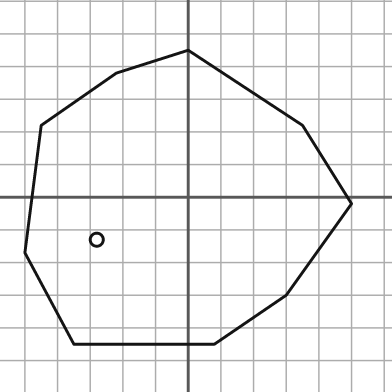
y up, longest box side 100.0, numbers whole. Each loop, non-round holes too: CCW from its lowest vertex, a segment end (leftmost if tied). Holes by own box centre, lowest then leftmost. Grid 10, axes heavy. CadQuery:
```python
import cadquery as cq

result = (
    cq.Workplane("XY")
    .moveTo(-35.0, -45.0)
    .lineTo(8.0, -45.0)
    .lineTo(30.0, -30.0)
    .lineTo(50.0, -2.0)
    .lineTo(35.0, 22.0)
    .lineTo(0.0, 45.0)
    .lineTo(-22.0, 38.0)
    .lineTo(-45.0, 22.0)
    .lineTo(-50.0, -17.0)
    .close()
    .moveTo(-28.0, -13.0)
    .circle(2.0)
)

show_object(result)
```